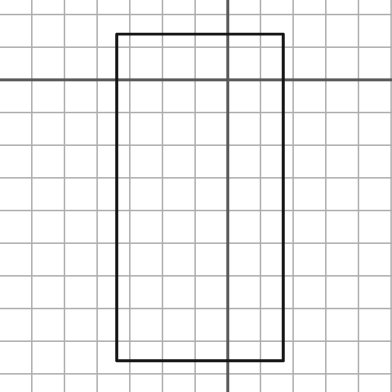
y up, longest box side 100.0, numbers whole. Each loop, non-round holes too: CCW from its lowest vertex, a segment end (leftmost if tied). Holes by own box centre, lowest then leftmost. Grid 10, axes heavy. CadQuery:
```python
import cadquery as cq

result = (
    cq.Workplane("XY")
    .moveTo(-34.0, -86.0)
    .lineTo(17.0, -86.0)
    .lineTo(17.0, 14.0)
    .lineTo(-34.0, 14.0)
    .close()
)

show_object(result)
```